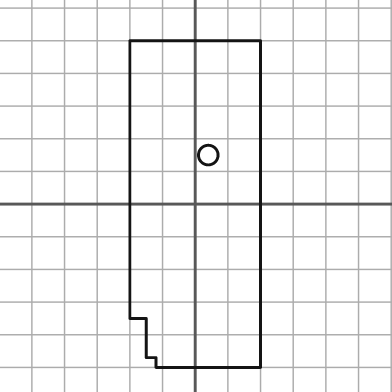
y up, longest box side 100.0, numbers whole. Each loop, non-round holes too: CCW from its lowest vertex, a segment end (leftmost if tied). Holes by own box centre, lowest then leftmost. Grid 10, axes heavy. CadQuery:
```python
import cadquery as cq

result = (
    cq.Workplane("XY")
    .moveTo(-12.0, -50.0)
    .lineTo(20.0, -50.0)
    .lineTo(20.0, 50.0)
    .lineTo(-20.0, 50.0)
    .lineTo(-20.0, -35.0)
    .lineTo(-15.0, -35.0)
    .lineTo(-15.0, -47.0)
    .lineTo(-12.0, -47.0)
    .close()
    .moveTo(4.0, 15.0)
    .circle(3.0)
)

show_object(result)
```